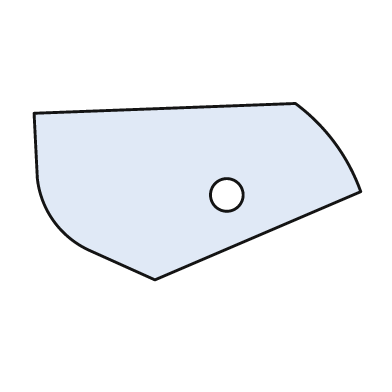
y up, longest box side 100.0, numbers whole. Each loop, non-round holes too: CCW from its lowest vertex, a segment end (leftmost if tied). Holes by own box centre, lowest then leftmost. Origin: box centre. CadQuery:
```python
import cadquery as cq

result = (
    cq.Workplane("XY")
    .moveTo(-13.0, -27.0)
    .lineTo(50.0, 0.0)
    .threePointArc((42.0, 15.0), (30.0, 27.0))
    .lineTo(-50.0, 24.0)
    .lineTo(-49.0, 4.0)
    .threePointArc((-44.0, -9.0), (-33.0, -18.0))
    .close()
    .moveTo(9.0, -1.0)
    .circle(5.0)
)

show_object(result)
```